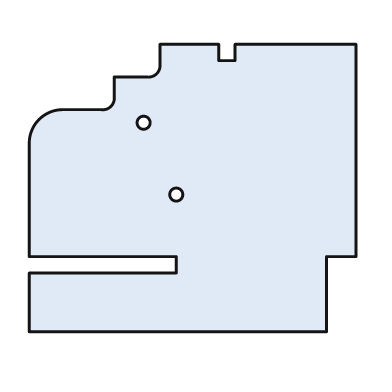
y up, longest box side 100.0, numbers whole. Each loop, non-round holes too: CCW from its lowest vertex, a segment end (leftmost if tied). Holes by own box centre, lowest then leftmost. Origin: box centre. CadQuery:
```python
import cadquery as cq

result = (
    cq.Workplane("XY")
    .moveTo(-50.0, -44.0)
    .lineTo(41.0, -44.0)
    .lineTo(41.0, -21.0)
    .lineTo(50.0, -21.0)
    .lineTo(50.0, 44.0)
    .lineTo(13.0, 44.0)
    .lineTo(13.0, 39.0)
    .lineTo(8.0, 39.0)
    .lineTo(8.0, 44.0)
    .lineTo(-10.0, 44.0)
    .lineTo(-10.0, 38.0)
    .threePointArc((-11.0, 35.0), (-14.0, 34.0))
    .lineTo(-24.0, 34.0)
    .lineTo(-24.0, 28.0)
    .threePointArc((-25.0, 25.0), (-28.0, 24.0))
    .lineTo(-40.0, 24.0)
    .threePointArc((-47.0, 21.0), (-50.0, 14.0))
    .lineTo(-50.0, -21.0)
    .lineTo(-5.0, -21.0)
    .lineTo(-5.0, -26.0)
    .lineTo(-50.0, -26.0)
    .close()
    .moveTo(-5.0, -2.0)
    .circle(2.0)
    .moveTo(-15.0, 20.0)
    .circle(2.0)
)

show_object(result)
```